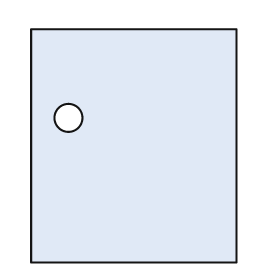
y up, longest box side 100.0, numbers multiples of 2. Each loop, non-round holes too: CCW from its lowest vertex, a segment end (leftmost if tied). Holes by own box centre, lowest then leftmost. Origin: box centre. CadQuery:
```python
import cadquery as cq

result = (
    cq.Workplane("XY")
    .moveTo(-44.0, -50.0)
    .lineTo(44.0, -50.0)
    .lineTo(44.0, 50.0)
    .lineTo(-44.0, 50.0)
    .close()
    .moveTo(-28.0, 12.0)
    .circle(6.0)
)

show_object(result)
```